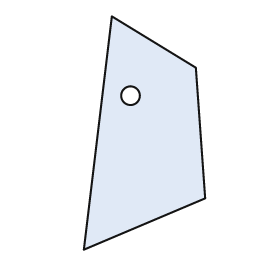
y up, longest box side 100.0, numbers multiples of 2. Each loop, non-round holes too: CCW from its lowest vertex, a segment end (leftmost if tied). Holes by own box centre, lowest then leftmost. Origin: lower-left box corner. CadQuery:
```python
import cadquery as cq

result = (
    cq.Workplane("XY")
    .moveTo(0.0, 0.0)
    .lineTo(52.0, 22.0)
    .lineTo(48.0, 78.0)
    .lineTo(12.0, 100.0)
    .close()
    .moveTo(20.0, 66.0)
    .circle(4.0)
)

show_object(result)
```